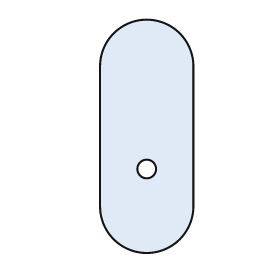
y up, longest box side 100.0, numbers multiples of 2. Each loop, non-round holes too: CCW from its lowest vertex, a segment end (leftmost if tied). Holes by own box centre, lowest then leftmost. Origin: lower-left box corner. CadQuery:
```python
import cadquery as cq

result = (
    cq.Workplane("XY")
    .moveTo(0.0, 20.0)
    .threePointArc((20.0, 0.0), (40.0, 20.0))
    .lineTo(40.0, 80.0)
    .threePointArc((20.0, 100.0), (0.0, 80.0))
    .close()
    .moveTo(20.0, 36.0)
    .circle(4.0)
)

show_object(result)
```